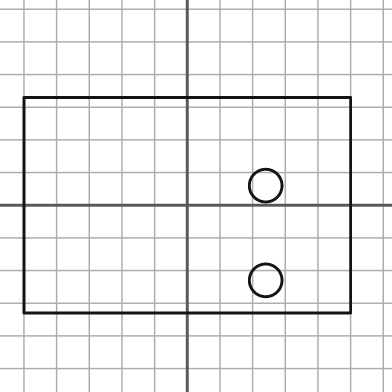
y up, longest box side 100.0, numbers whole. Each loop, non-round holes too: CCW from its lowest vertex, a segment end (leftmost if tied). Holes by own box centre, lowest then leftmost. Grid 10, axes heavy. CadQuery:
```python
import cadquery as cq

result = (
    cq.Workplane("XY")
    .moveTo(-50.0, -33.0)
    .lineTo(50.0, -33.0)
    .lineTo(50.0, 33.0)
    .lineTo(-50.0, 33.0)
    .close()
    .moveTo(24.0, -23.0)
    .circle(5.0)
    .moveTo(24.0, 6.0)
    .circle(5.0)
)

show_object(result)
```